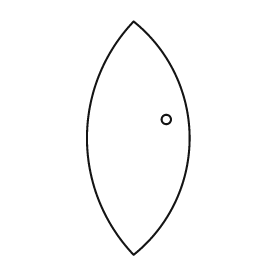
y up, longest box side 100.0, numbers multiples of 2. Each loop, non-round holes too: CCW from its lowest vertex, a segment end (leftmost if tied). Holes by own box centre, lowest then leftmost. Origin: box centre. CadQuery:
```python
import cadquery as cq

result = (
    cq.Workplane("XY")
    .moveTo(-2.0, -50.0)
    .threePointArc((22.0, 0.0), (-2.0, 50.0))
    .threePointArc((-22.0, 0.0), (-2.0, -50.0))
    .close()
    .moveTo(12.0, 8.0)
    .circle(2.0)
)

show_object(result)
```